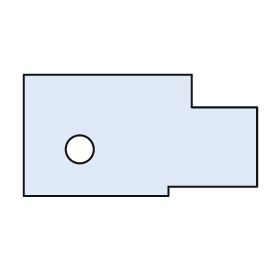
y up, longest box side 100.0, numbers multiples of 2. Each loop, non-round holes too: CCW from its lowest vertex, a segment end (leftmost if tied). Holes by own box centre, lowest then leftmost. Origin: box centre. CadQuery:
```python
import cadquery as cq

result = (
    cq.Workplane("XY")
    .moveTo(-50.0, -26.0)
    .lineTo(12.0, -26.0)
    .lineTo(12.0, -22.0)
    .lineTo(50.0, -22.0)
    .lineTo(50.0, 12.0)
    .lineTo(22.0, 12.0)
    .lineTo(22.0, 26.0)
    .lineTo(-50.0, 26.0)
    .close()
    .moveTo(-26.0, -6.0)
    .circle(6.0)
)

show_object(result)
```